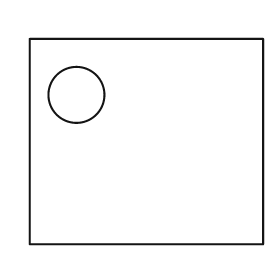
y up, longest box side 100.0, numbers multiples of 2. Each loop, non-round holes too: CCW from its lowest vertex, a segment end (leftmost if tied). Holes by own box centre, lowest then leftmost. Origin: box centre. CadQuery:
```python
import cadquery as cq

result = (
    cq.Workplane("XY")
    .moveTo(-50.0, -44.0)
    .lineTo(50.0, -44.0)
    .lineTo(50.0, 44.0)
    .lineTo(-50.0, 44.0)
    .close()
    .moveTo(-30.0, 20.0)
    .circle(12.0)
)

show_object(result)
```